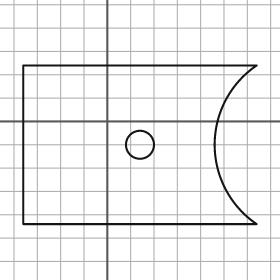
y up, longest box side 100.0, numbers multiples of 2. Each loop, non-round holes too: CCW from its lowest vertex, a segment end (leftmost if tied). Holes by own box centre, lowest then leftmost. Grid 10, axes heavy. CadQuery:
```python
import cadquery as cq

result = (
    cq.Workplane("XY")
    .moveTo(-36.0, -44.0)
    .lineTo(64.0, -44.0)
    .threePointArc((46.0, -10.0), (64.0, 24.0))
    .lineTo(-36.0, 24.0)
    .close()
    .moveTo(14.0, -10.0)
    .circle(6.0)
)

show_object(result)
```